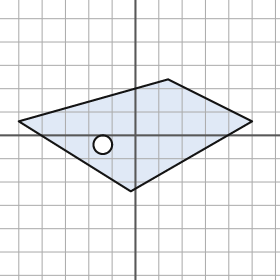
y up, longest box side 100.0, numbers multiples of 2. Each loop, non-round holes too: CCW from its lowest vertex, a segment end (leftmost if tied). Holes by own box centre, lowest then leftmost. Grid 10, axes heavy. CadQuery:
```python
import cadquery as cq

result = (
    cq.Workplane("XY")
    .moveTo(-2.0, -24.0)
    .lineTo(50.0, 6.0)
    .lineTo(14.0, 24.0)
    .lineTo(-50.0, 6.0)
    .close()
    .moveTo(-14.0, -4.0)
    .circle(4.0)
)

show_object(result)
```